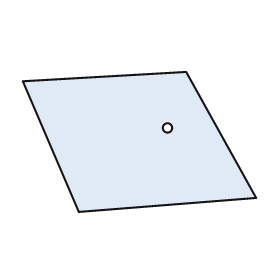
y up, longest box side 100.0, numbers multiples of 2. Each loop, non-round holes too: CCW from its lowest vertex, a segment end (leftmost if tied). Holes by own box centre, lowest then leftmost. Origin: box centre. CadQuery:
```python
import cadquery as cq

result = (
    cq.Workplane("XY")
    .moveTo(-26.0, -30.0)
    .lineTo(50.0, -24.0)
    .lineTo(20.0, 30.0)
    .lineTo(-50.0, 26.0)
    .close()
    .moveTo(12.0, 6.0)
    .circle(2.0)
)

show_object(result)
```